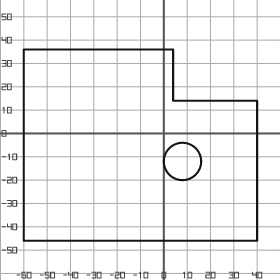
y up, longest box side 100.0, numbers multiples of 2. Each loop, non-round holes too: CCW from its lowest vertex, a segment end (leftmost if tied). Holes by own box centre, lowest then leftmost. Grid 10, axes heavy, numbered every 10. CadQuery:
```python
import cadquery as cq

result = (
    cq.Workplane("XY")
    .moveTo(-60.0, -46.0)
    .lineTo(40.0, -46.0)
    .lineTo(40.0, 14.0)
    .lineTo(4.0, 14.0)
    .lineTo(4.0, 36.0)
    .lineTo(-60.0, 36.0)
    .close()
    .moveTo(8.0, -12.0)
    .circle(8.0)
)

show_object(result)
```